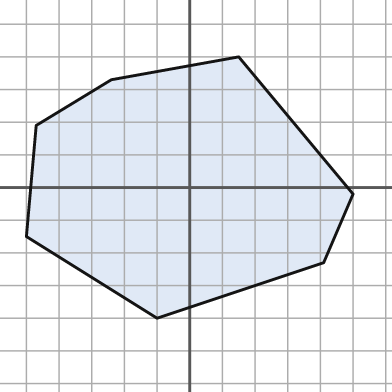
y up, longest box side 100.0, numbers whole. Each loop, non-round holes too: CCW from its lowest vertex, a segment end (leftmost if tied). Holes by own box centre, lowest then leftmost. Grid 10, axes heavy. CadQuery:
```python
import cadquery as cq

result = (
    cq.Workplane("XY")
    .moveTo(-10.0, -40.0)
    .lineTo(41.0, -23.0)
    .lineTo(50.0, -2.0)
    .lineTo(15.0, 40.0)
    .lineTo(-24.0, 33.0)
    .lineTo(-47.0, 19.0)
    .lineTo(-50.0, -15.0)
    .close()
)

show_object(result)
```